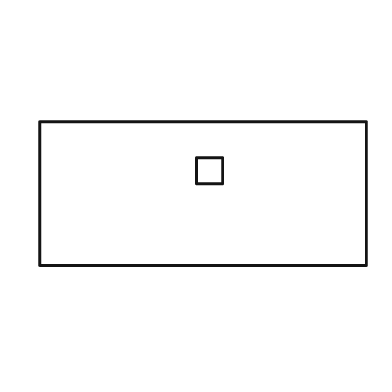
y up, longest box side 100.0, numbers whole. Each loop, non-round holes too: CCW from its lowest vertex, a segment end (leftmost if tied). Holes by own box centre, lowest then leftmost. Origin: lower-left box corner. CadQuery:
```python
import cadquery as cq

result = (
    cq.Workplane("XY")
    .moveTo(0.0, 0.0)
    .lineTo(100.0, 0.0)
    .lineTo(100.0, 44.0)
    .lineTo(0.0, 44.0)
    .close()
    .moveTo(48.0, 25.0)
    .lineTo(56.0, 25.0)
    .lineTo(56.0, 33.0)
    .lineTo(48.0, 33.0)
    .close()
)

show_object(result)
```